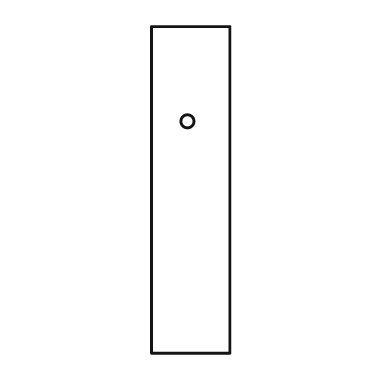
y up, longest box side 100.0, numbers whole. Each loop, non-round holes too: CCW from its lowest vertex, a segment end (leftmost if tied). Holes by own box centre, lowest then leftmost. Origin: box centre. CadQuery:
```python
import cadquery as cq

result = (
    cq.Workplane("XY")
    .moveTo(-12.0, -50.0)
    .lineTo(12.0, -50.0)
    .lineTo(12.0, 50.0)
    .lineTo(-12.0, 50.0)
    .close()
    .moveTo(-1.0, 21.0)
    .circle(2.0)
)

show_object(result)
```